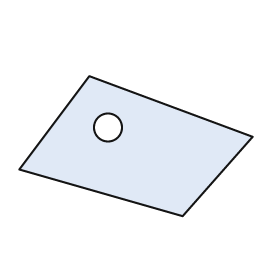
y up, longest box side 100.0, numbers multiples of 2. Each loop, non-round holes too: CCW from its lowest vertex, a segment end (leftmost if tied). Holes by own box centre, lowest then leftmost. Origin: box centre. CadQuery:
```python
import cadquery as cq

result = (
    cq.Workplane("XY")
    .moveTo(20.0, -30.0)
    .lineTo(50.0, 4.0)
    .lineTo(-20.0, 30.0)
    .lineTo(-50.0, -10.0)
    .close()
    .moveTo(-12.0, 8.0)
    .circle(6.0)
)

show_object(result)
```